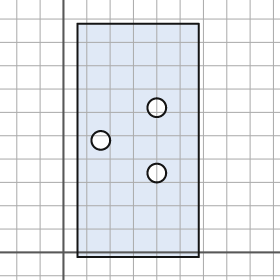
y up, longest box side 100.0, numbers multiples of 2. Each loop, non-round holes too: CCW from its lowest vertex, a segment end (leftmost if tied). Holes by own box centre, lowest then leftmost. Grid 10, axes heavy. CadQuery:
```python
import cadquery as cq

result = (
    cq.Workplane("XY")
    .moveTo(6.0, -2.0)
    .lineTo(58.0, -2.0)
    .lineTo(58.0, 98.0)
    .lineTo(6.0, 98.0)
    .close()
    .moveTo(40.0, 34.0)
    .circle(4.0)
    .moveTo(16.0, 48.0)
    .circle(4.0)
    .moveTo(40.0, 62.0)
    .circle(4.0)
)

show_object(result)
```